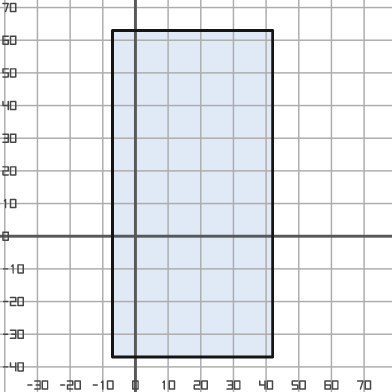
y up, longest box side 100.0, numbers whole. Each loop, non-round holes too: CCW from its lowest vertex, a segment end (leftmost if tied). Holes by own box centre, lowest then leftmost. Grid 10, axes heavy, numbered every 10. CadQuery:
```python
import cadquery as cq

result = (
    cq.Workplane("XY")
    .moveTo(-7.0, -37.0)
    .lineTo(42.0, -37.0)
    .lineTo(42.0, 63.0)
    .lineTo(-7.0, 63.0)
    .close()
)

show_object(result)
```